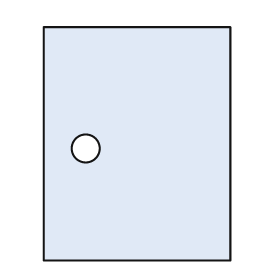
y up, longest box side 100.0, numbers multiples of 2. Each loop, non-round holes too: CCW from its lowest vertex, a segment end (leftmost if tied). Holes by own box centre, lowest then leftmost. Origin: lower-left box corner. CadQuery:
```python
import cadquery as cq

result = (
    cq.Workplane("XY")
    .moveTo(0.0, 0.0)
    .lineTo(80.0, 0.0)
    .lineTo(80.0, 100.0)
    .lineTo(0.0, 100.0)
    .close()
    .moveTo(18.0, 48.0)
    .circle(6.0)
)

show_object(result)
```